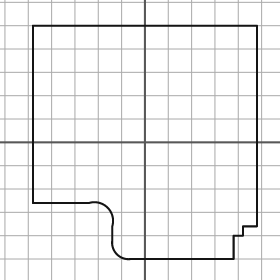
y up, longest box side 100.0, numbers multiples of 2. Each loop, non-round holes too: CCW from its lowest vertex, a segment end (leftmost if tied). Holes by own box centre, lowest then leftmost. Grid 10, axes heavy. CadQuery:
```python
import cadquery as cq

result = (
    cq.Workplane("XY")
    .moveTo(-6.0, -50.0)
    .lineTo(38.0, -50.0)
    .lineTo(38.0, -40.0)
    .lineTo(42.0, -40.0)
    .lineTo(42.0, -36.0)
    .lineTo(48.0, -36.0)
    .lineTo(48.0, 50.0)
    .lineTo(-48.0, 50.0)
    .lineTo(-48.0, -26.0)
    .lineTo(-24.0, -26.0)
    .threePointArc((-16.0, -28.0), (-14.0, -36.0))
    .lineTo(-14.0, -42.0)
    .threePointArc((-12.0, -48.0), (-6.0, -50.0))
    .close()
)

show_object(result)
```